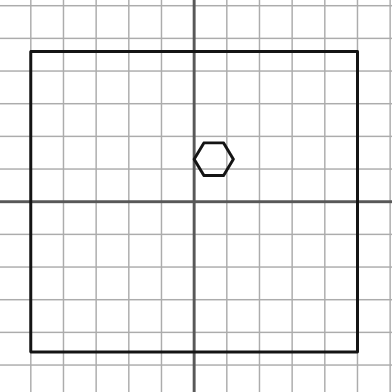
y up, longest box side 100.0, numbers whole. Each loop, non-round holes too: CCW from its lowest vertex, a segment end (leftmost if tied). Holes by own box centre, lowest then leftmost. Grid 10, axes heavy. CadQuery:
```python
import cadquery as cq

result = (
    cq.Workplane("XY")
    .moveTo(-50.0, -46.0)
    .lineTo(50.0, -46.0)
    .lineTo(50.0, 46.0)
    .lineTo(-50.0, 46.0)
    .close()
    .moveTo(3.0, 8.0)
    .lineTo(9.0, 8.0)
    .lineTo(12.0, 13.0)
    .lineTo(9.0, 18.0)
    .lineTo(3.0, 18.0)
    .lineTo(0.0, 13.0)
    .close()
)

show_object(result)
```